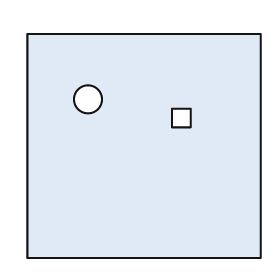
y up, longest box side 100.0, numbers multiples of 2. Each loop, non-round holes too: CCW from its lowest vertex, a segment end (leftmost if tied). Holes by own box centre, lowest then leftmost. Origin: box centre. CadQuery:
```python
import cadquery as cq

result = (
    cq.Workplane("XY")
    .moveTo(-50.0, -48.0)
    .lineTo(50.0, -48.0)
    .lineTo(50.0, 48.0)
    .lineTo(-50.0, 48.0)
    .close()
    .moveTo(12.0, 8.0)
    .lineTo(20.0, 8.0)
    .lineTo(20.0, 16.0)
    .lineTo(12.0, 16.0)
    .close()
    .moveTo(-24.0, 20.0)
    .circle(6.0)
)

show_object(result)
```